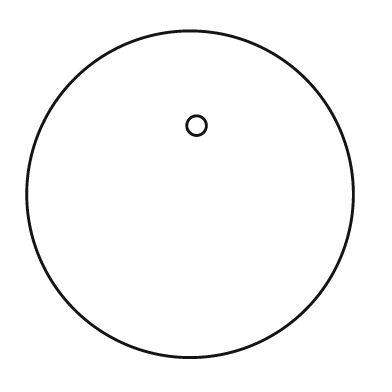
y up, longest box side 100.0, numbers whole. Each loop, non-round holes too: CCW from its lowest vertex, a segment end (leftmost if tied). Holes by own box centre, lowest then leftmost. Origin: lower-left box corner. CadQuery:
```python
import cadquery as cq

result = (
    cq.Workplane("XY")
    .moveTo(50.0, 50.0)
    .circle(50.0)
    .moveTo(52.0, 71.0)
    .circle(3.0)
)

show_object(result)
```